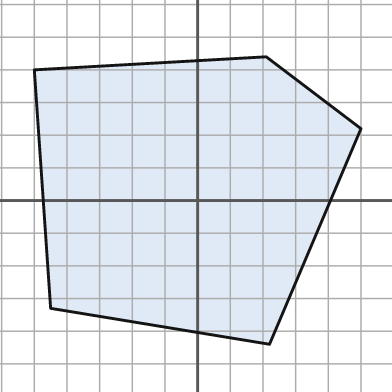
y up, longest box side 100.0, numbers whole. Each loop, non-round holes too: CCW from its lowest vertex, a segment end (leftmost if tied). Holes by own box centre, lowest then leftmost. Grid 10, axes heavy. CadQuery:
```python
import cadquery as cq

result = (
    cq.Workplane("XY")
    .moveTo(22.0, -44.0)
    .lineTo(50.0, 22.0)
    .lineTo(21.0, 44.0)
    .lineTo(-50.0, 40.0)
    .lineTo(-45.0, -33.0)
    .close()
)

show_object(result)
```